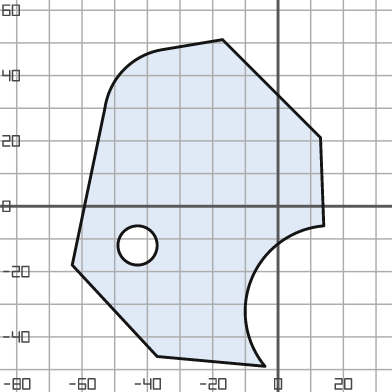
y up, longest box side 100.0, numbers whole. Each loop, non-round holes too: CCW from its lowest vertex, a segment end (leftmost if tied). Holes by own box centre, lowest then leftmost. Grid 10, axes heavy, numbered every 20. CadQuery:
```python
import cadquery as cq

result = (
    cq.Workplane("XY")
    .moveTo(-4.0, -49.0)
    .threePointArc((-8.0, -22.0), (14.0, -6.0))
    .lineTo(13.0, 21.0)
    .lineTo(-17.0, 51.0)
    .lineTo(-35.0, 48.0)
    .threePointArc((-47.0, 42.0), (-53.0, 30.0))
    .lineTo(-63.0, -18.0)
    .lineTo(-37.0, -46.0)
    .close()
    .moveTo(-43.0, -12.0)
    .circle(6.0)
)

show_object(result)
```